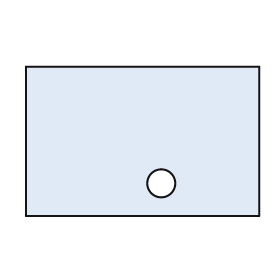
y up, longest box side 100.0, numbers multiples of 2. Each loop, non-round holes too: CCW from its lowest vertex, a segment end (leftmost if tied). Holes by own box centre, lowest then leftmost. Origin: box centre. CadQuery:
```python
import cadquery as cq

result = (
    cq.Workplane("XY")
    .moveTo(-50.0, -32.0)
    .lineTo(50.0, -32.0)
    .lineTo(50.0, 32.0)
    .lineTo(-50.0, 32.0)
    .close()
    .moveTo(8.0, -18.0)
    .circle(6.0)
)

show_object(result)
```